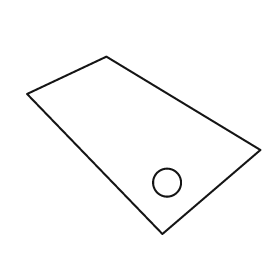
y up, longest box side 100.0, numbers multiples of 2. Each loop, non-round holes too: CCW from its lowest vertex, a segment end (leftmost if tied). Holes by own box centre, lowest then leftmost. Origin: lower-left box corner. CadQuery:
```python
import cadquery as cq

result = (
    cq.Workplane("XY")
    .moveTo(58.0, 0.0)
    .lineTo(100.0, 36.0)
    .lineTo(34.0, 76.0)
    .lineTo(0.0, 60.0)
    .close()
    .moveTo(60.0, 22.0)
    .circle(6.0)
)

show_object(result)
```